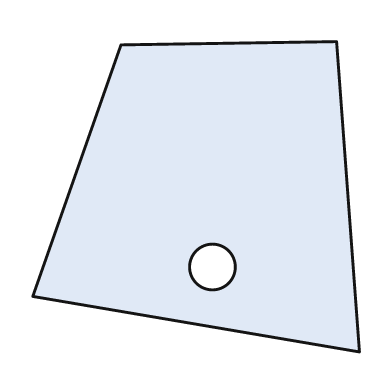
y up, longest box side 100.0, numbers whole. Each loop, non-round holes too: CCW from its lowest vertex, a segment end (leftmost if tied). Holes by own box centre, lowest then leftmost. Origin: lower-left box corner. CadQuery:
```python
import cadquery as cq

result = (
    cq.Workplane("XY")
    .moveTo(100.0, 0.0)
    .lineTo(93.0, 95.0)
    .lineTo(27.0, 94.0)
    .lineTo(0.0, 17.0)
    .close()
    .moveTo(55.0, 26.0)
    .circle(7.0)
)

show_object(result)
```